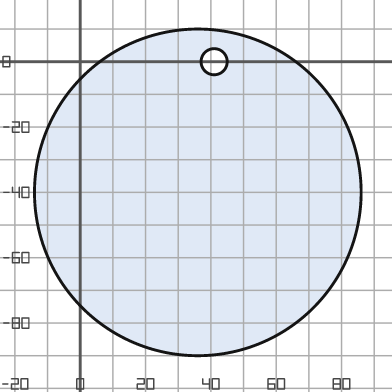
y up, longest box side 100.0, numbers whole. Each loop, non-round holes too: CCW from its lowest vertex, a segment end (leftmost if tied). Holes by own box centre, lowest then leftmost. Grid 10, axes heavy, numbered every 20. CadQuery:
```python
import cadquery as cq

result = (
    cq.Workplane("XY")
    .moveTo(36.0, -40.0)
    .circle(50.0)
    .moveTo(41.0, 0.0)
    .circle(4.0)
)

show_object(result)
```